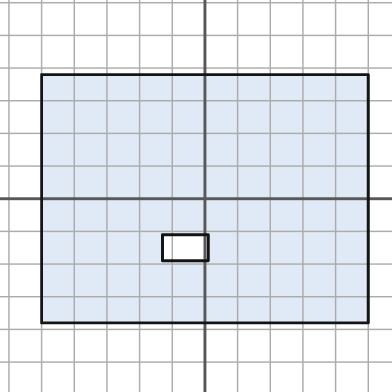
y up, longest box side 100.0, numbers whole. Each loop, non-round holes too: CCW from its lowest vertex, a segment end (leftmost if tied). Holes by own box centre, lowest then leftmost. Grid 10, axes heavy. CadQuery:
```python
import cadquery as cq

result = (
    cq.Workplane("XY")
    .moveTo(-50.0, -38.0)
    .lineTo(50.0, -38.0)
    .lineTo(50.0, 38.0)
    .lineTo(-50.0, 38.0)
    .close()
    .moveTo(-13.0, -19.0)
    .lineTo(1.0, -19.0)
    .lineTo(1.0, -11.0)
    .lineTo(-13.0, -11.0)
    .close()
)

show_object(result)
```